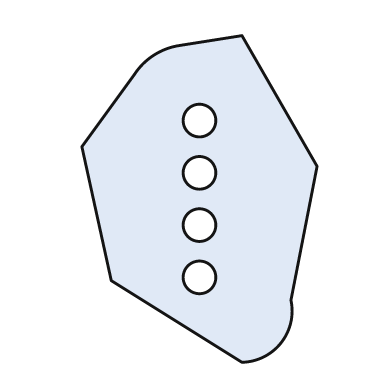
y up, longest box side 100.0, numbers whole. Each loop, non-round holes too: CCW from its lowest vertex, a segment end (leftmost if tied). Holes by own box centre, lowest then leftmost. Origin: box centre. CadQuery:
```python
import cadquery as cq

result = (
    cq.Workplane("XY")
    .moveTo(13.0, -50.0)
    .threePointArc((25.0, -44.0), (28.0, -31.0))
    .lineTo(36.0, 10.0)
    .lineTo(13.0, 50.0)
    .lineTo(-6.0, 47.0)
    .threePointArc((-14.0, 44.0), (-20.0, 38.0))
    .lineTo(-36.0, 16.0)
    .lineTo(-27.0, -25.0)
    .close()
    .moveTo(0.0, -24.0)
    .circle(5.0)
    .moveTo(0.0, -8.0)
    .circle(5.0)
    .moveTo(0.0, 8.0)
    .circle(5.0)
    .moveTo(0.0, 24.0)
    .circle(5.0)
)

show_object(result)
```